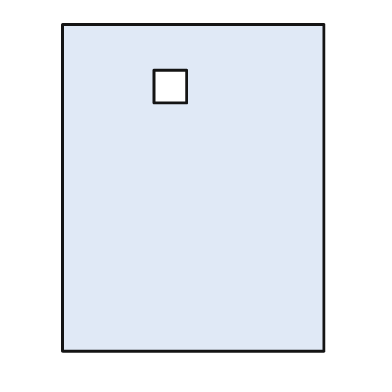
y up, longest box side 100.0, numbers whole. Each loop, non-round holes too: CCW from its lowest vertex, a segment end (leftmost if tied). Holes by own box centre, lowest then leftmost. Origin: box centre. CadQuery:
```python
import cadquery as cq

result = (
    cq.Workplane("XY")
    .moveTo(-40.0, -50.0)
    .lineTo(40.0, -50.0)
    .lineTo(40.0, 50.0)
    .lineTo(-40.0, 50.0)
    .close()
    .moveTo(-12.0, 26.0)
    .lineTo(-2.0, 26.0)
    .lineTo(-2.0, 36.0)
    .lineTo(-12.0, 36.0)
    .close()
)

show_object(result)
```